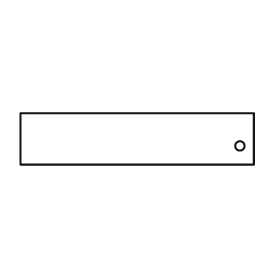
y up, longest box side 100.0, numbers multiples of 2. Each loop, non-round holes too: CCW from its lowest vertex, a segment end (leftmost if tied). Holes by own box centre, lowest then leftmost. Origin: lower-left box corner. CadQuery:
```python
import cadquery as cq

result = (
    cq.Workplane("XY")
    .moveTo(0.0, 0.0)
    .lineTo(100.0, 0.0)
    .lineTo(100.0, 22.0)
    .lineTo(0.0, 22.0)
    .close()
    .moveTo(94.0, 8.0)
    .circle(2.0)
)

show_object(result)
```